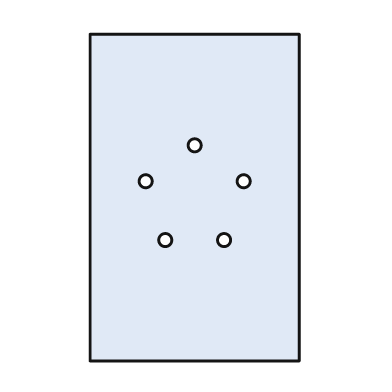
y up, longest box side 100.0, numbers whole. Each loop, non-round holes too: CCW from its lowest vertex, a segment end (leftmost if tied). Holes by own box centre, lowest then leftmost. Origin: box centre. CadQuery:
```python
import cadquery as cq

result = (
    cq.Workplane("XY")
    .moveTo(-32.0, -50.0)
    .lineTo(32.0, -50.0)
    .lineTo(32.0, 50.0)
    .lineTo(-32.0, 50.0)
    .close()
    .moveTo(-9.0, -13.0)
    .circle(2.0)
    .moveTo(9.0, -13.0)
    .circle(2.0)
    .moveTo(-15.0, 5.0)
    .circle(2.0)
    .moveTo(15.0, 5.0)
    .circle(2.0)
    .moveTo(0.0, 16.0)
    .circle(2.0)
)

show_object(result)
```